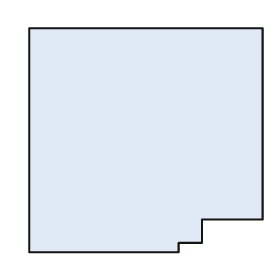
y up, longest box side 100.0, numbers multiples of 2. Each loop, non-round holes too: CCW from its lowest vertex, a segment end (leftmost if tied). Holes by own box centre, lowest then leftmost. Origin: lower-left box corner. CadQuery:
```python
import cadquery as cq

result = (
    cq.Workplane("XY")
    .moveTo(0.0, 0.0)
    .lineTo(64.0, 0.0)
    .lineTo(64.0, 4.0)
    .lineTo(74.0, 4.0)
    .lineTo(74.0, 14.0)
    .lineTo(100.0, 14.0)
    .lineTo(100.0, 96.0)
    .lineTo(0.0, 96.0)
    .close()
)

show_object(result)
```